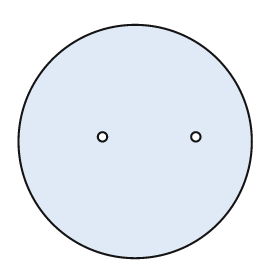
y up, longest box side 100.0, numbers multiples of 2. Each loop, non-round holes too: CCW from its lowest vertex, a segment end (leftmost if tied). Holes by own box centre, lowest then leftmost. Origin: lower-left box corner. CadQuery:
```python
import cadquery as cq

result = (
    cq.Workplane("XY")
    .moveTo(50.0, 50.0)
    .circle(50.0)
    .moveTo(36.0, 52.0)
    .circle(2.0)
    .moveTo(76.0, 52.0)
    .circle(2.0)
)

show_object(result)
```